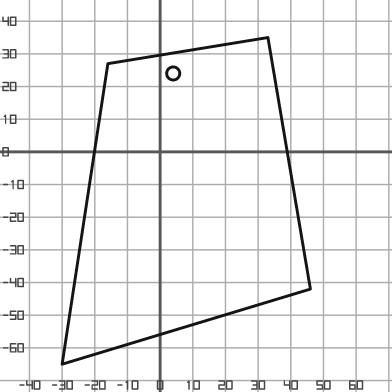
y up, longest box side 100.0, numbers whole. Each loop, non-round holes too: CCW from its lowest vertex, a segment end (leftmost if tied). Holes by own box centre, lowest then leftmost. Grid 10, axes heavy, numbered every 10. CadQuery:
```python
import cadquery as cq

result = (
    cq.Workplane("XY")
    .moveTo(-30.0, -65.0)
    .lineTo(46.0, -42.0)
    .lineTo(33.0, 35.0)
    .lineTo(-16.0, 27.0)
    .close()
    .moveTo(4.0, 24.0)
    .circle(2.0)
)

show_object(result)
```